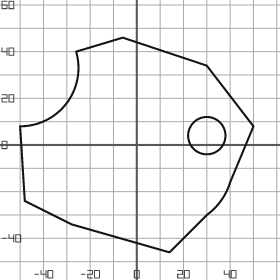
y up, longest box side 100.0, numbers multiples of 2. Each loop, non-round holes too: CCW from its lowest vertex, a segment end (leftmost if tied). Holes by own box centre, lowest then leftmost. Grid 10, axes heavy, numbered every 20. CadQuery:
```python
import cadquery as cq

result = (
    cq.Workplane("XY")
    .moveTo(14.0, -46.0)
    .lineTo(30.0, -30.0)
    .threePointArc((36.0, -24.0), (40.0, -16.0))
    .lineTo(50.0, 8.0)
    .lineTo(30.0, 34.0)
    .lineTo(-6.0, 46.0)
    .lineTo(-26.0, 40.0)
    .threePointArc((-30.0, 18.0), (-50.0, 8.0))
    .lineTo(-48.0, -24.0)
    .lineTo(-28.0, -34.0)
    .close()
    .moveTo(30.0, 4.0)
    .circle(8.0)
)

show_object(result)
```